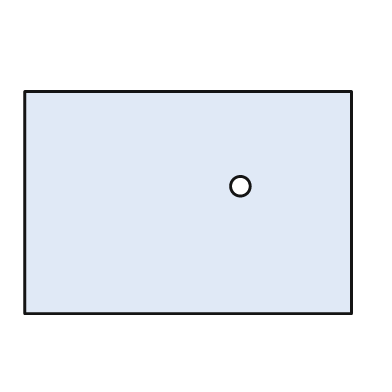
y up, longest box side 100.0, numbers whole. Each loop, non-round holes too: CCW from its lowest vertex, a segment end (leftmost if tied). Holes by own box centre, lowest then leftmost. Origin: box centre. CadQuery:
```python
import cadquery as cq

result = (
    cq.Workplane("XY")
    .moveTo(-50.0, -34.0)
    .lineTo(50.0, -34.0)
    .lineTo(50.0, 34.0)
    .lineTo(-50.0, 34.0)
    .close()
    .moveTo(16.0, 5.0)
    .circle(3.0)
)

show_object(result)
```